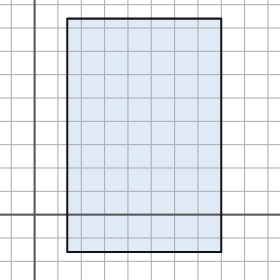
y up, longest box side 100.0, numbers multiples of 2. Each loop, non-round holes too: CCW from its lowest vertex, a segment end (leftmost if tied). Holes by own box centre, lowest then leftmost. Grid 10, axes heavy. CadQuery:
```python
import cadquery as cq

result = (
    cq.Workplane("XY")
    .moveTo(14.0, -16.0)
    .lineTo(80.0, -16.0)
    .lineTo(80.0, 84.0)
    .lineTo(14.0, 84.0)
    .close()
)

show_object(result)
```